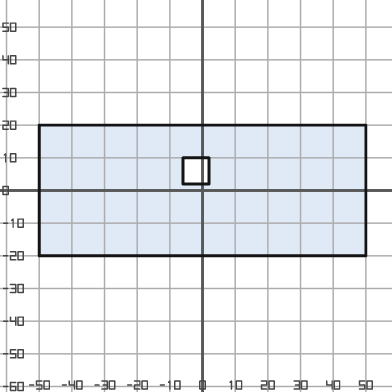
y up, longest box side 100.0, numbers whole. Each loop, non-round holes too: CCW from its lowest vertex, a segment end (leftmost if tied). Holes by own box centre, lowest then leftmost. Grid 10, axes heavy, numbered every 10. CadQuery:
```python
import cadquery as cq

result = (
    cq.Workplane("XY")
    .moveTo(-50.0, -20.0)
    .lineTo(50.0, -20.0)
    .lineTo(50.0, 20.0)
    .lineTo(-50.0, 20.0)
    .close()
    .moveTo(-6.0, 2.0)
    .lineTo(2.0, 2.0)
    .lineTo(2.0, 10.0)
    .lineTo(-6.0, 10.0)
    .close()
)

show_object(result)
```